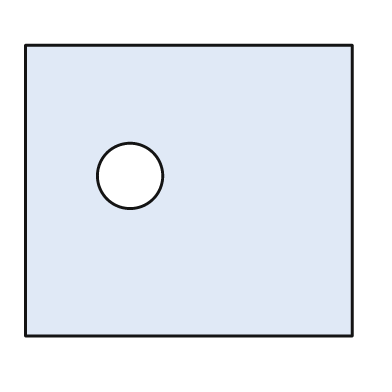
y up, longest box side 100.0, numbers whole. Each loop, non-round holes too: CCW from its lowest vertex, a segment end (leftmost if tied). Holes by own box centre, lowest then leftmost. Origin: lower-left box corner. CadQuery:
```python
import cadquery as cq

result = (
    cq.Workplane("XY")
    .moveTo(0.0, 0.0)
    .lineTo(100.0, 0.0)
    .lineTo(100.0, 89.0)
    .lineTo(0.0, 89.0)
    .close()
    .moveTo(32.0, 49.0)
    .circle(10.0)
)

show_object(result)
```